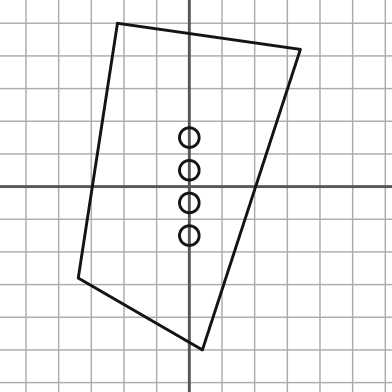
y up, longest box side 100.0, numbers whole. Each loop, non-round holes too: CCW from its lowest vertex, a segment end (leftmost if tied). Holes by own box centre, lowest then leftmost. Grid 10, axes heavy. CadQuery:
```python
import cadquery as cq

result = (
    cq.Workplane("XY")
    .moveTo(4.0, -50.0)
    .lineTo(34.0, 42.0)
    .lineTo(-22.0, 50.0)
    .lineTo(-34.0, -28.0)
    .close()
    .moveTo(0.0, -15.0)
    .circle(3.0)
    .moveTo(0.0, -5.0)
    .circle(3.0)
    .moveTo(0.0, 5.0)
    .circle(3.0)
    .moveTo(0.0, 15.0)
    .circle(3.0)
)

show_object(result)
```